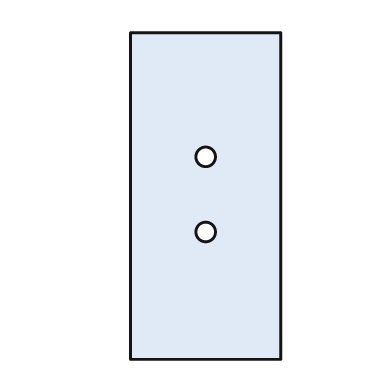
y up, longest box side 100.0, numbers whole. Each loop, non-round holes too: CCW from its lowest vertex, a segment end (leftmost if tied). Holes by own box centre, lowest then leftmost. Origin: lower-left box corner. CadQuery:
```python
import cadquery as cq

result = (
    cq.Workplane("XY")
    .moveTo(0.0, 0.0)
    .lineTo(46.0, 0.0)
    .lineTo(46.0, 100.0)
    .lineTo(0.0, 100.0)
    .close()
    .moveTo(23.0, 39.0)
    .circle(3.0)
    .moveTo(23.0, 62.0)
    .circle(3.0)
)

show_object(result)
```